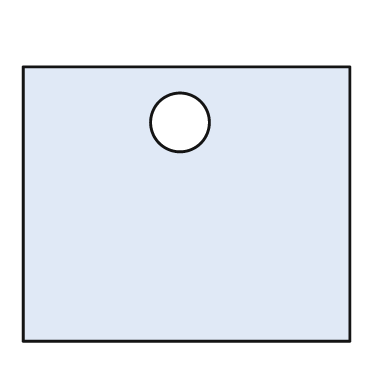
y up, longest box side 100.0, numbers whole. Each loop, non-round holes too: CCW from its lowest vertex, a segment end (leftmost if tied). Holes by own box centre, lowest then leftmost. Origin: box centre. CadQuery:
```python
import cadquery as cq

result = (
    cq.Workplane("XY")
    .moveTo(-50.0, -42.0)
    .lineTo(50.0, -42.0)
    .lineTo(50.0, 42.0)
    .lineTo(-50.0, 42.0)
    .close()
    .moveTo(-2.0, 25.0)
    .circle(9.0)
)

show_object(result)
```